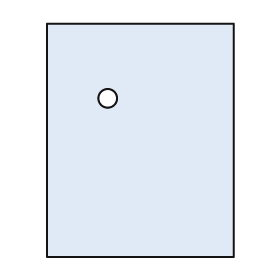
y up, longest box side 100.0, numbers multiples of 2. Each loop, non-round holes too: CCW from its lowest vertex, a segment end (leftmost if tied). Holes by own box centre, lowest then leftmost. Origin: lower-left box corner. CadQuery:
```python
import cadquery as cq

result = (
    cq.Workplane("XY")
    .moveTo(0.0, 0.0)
    .lineTo(80.0, 0.0)
    .lineTo(80.0, 100.0)
    .lineTo(0.0, 100.0)
    .close()
    .moveTo(26.0, 68.0)
    .circle(4.0)
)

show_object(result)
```